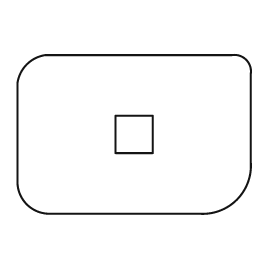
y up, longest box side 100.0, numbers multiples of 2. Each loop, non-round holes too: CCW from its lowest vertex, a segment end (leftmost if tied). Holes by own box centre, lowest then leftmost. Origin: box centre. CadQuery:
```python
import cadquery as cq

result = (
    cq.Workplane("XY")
    .moveTo(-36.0, -34.0)
    .lineTo(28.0, -34.0)
    .threePointArc((44.0, -28.0), (50.0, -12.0))
    .lineTo(50.0, 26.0)
    .threePointArc((48.0, 32.0), (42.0, 34.0))
    .lineTo(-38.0, 34.0)
    .threePointArc((-46.0, 30.0), (-50.0, 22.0))
    .lineTo(-50.0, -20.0)
    .threePointArc((-46.0, -30.0), (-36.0, -34.0))
    .close()
    .moveTo(-8.0, -8.0)
    .lineTo(8.0, -8.0)
    .lineTo(8.0, 8.0)
    .lineTo(-8.0, 8.0)
    .close()
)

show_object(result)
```